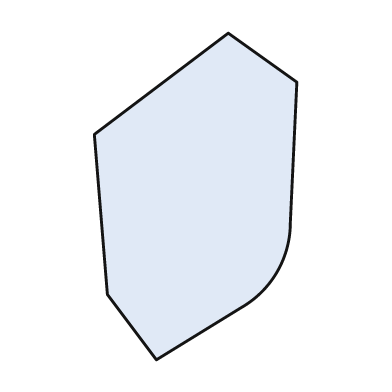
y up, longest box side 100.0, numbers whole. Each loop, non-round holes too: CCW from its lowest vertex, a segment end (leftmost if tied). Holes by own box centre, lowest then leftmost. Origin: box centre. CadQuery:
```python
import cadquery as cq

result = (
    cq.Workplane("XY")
    .moveTo(-12.0, -50.0)
    .lineTo(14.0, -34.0)
    .threePointArc((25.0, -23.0), (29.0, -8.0))
    .lineTo(31.0, 35.0)
    .lineTo(10.0, 50.0)
    .lineTo(-31.0, 19.0)
    .lineTo(-27.0, -30.0)
    .close()
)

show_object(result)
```